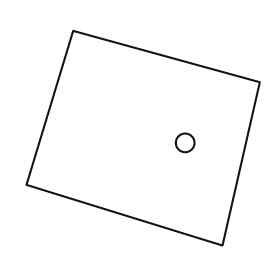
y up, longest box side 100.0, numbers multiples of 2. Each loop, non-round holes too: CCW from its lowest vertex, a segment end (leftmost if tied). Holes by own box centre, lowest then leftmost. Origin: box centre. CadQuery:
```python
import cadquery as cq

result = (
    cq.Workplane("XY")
    .moveTo(34.0, -46.0)
    .lineTo(50.0, 24.0)
    .lineTo(-30.0, 46.0)
    .lineTo(-50.0, -20.0)
    .close()
    .moveTo(18.0, -2.0)
    .circle(4.0)
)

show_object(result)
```